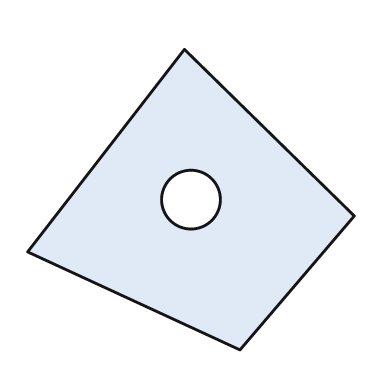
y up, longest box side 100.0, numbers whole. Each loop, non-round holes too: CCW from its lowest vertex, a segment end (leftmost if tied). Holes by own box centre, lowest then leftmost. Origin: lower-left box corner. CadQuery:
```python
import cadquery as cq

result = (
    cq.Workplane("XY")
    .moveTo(65.0, 0.0)
    .lineTo(100.0, 41.0)
    .lineTo(48.0, 92.0)
    .lineTo(0.0, 30.0)
    .close()
    .moveTo(50.0, 46.0)
    .circle(9.0)
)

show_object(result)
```